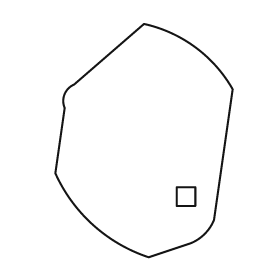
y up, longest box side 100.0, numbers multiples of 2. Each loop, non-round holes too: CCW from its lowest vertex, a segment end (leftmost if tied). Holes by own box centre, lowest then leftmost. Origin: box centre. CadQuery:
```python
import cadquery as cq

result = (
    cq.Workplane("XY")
    .moveTo(2.0, -50.0)
    .lineTo(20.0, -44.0)
    .threePointArc((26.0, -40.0), (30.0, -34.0))
    .lineTo(38.0, 22.0)
    .threePointArc((22.0, 40.0), (0.0, 50.0))
    .lineTo(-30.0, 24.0)
    .threePointArc((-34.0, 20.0), (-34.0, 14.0))
    .lineTo(-38.0, -14.0)
    .threePointArc((-22.0, -36.0), (2.0, -50.0))
    .close()
    .moveTo(14.0, -28.0)
    .lineTo(22.0, -28.0)
    .lineTo(22.0, -20.0)
    .lineTo(14.0, -20.0)
    .close()
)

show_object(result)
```